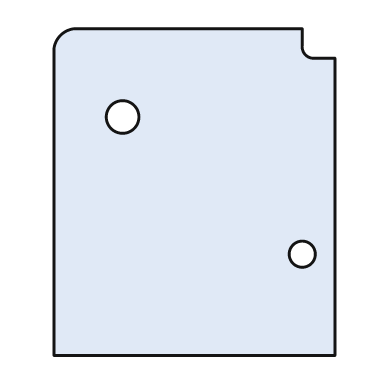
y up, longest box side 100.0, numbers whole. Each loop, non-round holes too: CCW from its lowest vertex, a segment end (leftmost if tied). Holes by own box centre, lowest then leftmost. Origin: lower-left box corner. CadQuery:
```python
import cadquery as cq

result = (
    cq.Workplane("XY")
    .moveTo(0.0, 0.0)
    .lineTo(86.0, 0.0)
    .lineTo(86.0, 91.0)
    .lineTo(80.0, 91.0)
    .threePointArc((77.0, 92.0), (76.0, 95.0))
    .lineTo(76.0, 100.0)
    .lineTo(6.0, 100.0)
    .threePointArc((2.0, 98.0), (0.0, 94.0))
    .close()
    .moveTo(76.0, 31.0)
    .circle(4.0)
    .moveTo(21.0, 73.0)
    .circle(5.0)
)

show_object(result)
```